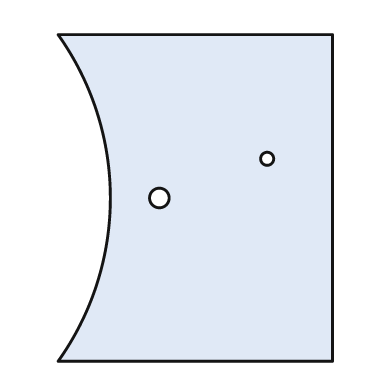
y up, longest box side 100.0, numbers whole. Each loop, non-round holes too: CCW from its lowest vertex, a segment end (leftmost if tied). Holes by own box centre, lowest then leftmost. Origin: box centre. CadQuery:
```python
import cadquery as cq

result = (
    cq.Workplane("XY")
    .moveTo(-42.0, -50.0)
    .lineTo(42.0, -50.0)
    .lineTo(42.0, 50.0)
    .lineTo(-42.0, 50.0)
    .threePointArc((-26.0, 0.0), (-42.0, -50.0))
    .close()
    .moveTo(-11.0, 0.0)
    .circle(3.0)
    .moveTo(22.0, 12.0)
    .circle(2.0)
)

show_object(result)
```